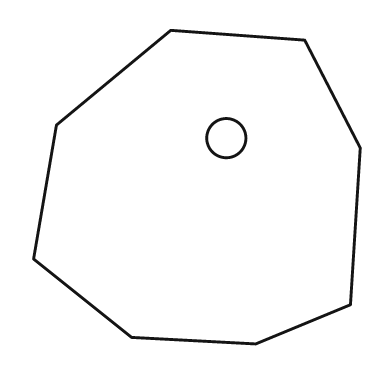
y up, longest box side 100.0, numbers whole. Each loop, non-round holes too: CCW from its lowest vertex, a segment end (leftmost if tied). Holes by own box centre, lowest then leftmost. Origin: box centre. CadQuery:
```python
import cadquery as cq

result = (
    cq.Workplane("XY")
    .moveTo(18.0, -48.0)
    .lineTo(47.0, -36.0)
    .lineTo(50.0, 12.0)
    .lineTo(33.0, 45.0)
    .lineTo(-8.0, 48.0)
    .lineTo(-43.0, 19.0)
    .lineTo(-50.0, -22.0)
    .lineTo(-20.0, -46.0)
    .close()
    .moveTo(9.0, 15.0)
    .circle(6.0)
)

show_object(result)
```